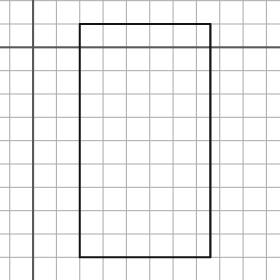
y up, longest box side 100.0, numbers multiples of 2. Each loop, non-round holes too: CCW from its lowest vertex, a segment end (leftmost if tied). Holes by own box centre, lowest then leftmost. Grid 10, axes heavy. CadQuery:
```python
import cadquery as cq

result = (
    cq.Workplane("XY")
    .moveTo(20.0, -90.0)
    .lineTo(76.0, -90.0)
    .lineTo(76.0, 10.0)
    .lineTo(20.0, 10.0)
    .close()
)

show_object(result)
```